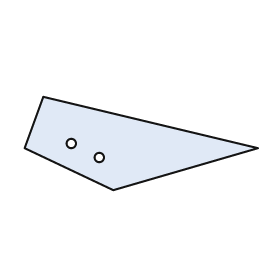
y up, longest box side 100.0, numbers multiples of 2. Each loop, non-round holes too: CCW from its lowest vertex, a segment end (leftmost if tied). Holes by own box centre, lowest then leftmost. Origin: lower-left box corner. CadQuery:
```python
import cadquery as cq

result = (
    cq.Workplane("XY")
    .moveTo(38.0, 0.0)
    .lineTo(100.0, 18.0)
    .lineTo(8.0, 40.0)
    .lineTo(0.0, 18.0)
    .close()
    .moveTo(32.0, 14.0)
    .circle(2.0)
    .moveTo(20.0, 20.0)
    .circle(2.0)
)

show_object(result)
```